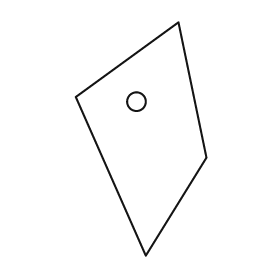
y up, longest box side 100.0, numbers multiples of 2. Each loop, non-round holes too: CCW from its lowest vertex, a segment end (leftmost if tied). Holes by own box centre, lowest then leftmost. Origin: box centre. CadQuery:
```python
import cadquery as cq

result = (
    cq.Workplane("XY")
    .moveTo(2.0, -50.0)
    .lineTo(28.0, -8.0)
    .lineTo(16.0, 50.0)
    .lineTo(-28.0, 18.0)
    .close()
    .moveTo(-2.0, 16.0)
    .circle(4.0)
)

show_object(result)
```